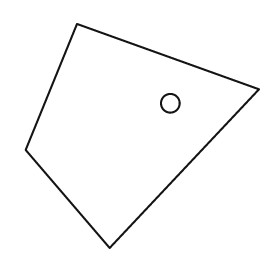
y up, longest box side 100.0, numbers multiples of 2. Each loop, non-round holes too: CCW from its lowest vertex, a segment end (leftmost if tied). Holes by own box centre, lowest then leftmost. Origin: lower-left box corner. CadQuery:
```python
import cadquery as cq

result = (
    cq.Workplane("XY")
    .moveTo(36.0, 0.0)
    .lineTo(100.0, 68.0)
    .lineTo(22.0, 96.0)
    .lineTo(0.0, 42.0)
    .close()
    .moveTo(62.0, 62.0)
    .circle(4.0)
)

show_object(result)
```